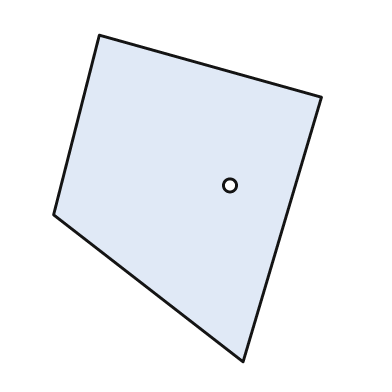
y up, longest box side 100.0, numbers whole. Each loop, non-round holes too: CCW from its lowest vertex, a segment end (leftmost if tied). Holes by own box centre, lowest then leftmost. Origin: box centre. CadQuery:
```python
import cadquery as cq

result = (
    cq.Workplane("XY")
    .moveTo(17.0, -50.0)
    .lineTo(41.0, 31.0)
    .lineTo(-27.0, 50.0)
    .lineTo(-41.0, -5.0)
    .close()
    .moveTo(13.0, 4.0)
    .circle(2.0)
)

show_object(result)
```